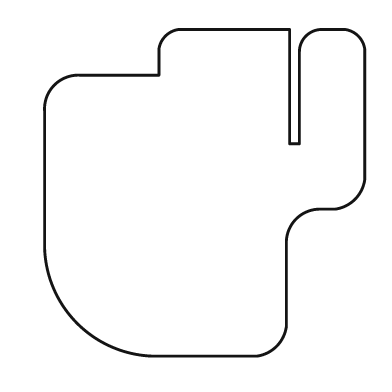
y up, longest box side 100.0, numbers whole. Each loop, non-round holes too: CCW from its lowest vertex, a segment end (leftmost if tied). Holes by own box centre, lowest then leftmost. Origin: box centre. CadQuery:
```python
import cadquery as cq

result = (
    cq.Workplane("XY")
    .moveTo(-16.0, -50.0)
    .lineTo(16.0, -50.0)
    .threePointArc((22.0, -47.0), (25.0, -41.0))
    .lineTo(25.0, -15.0)
    .threePointArc((28.0, -8.0), (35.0, -5.0))
    .lineTo(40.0, -5.0)
    .threePointArc((46.0, -2.0), (49.0, 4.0))
    .lineTo(49.0, 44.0)
    .threePointArc((47.0, 48.0), (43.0, 50.0))
    .lineTo(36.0, 50.0)
    .threePointArc((31.0, 48.0), (29.0, 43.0))
    .lineTo(29.0, 15.0)
    .lineTo(26.0, 15.0)
    .lineTo(26.0, 50.0)
    .lineTo(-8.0, 50.0)
    .threePointArc((-12.0, 48.0), (-14.0, 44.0))
    .lineTo(-14.0, 36.0)
    .lineTo(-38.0, 36.0)
    .threePointArc((-46.0, 33.0), (-49.0, 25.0))
    .lineTo(-49.0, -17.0)
    .threePointArc((-39.0, -40.0), (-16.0, -50.0))
    .close()
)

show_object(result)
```